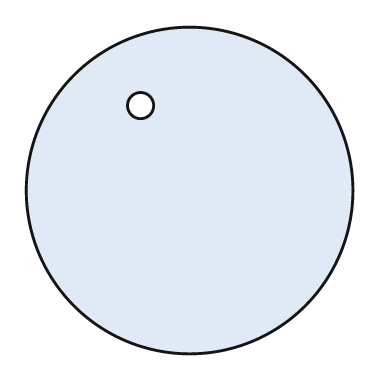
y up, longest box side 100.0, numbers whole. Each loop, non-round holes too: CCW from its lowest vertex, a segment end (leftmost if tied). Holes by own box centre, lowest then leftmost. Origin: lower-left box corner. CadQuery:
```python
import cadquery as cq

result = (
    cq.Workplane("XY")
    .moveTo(50.0, 50.0)
    .circle(50.0)
    .moveTo(35.0, 76.0)
    .circle(4.0)
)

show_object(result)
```